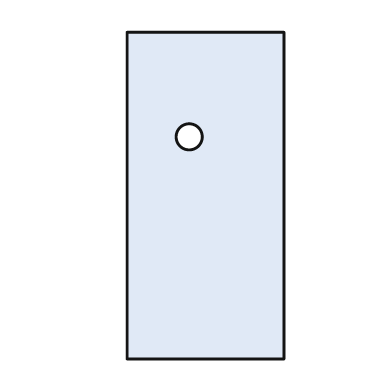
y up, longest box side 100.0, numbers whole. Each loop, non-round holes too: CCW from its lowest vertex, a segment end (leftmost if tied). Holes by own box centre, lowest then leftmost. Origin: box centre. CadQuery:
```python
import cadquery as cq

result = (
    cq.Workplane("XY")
    .moveTo(-24.0, -50.0)
    .lineTo(24.0, -50.0)
    .lineTo(24.0, 50.0)
    .lineTo(-24.0, 50.0)
    .close()
    .moveTo(-5.0, 18.0)
    .circle(4.0)
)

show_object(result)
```